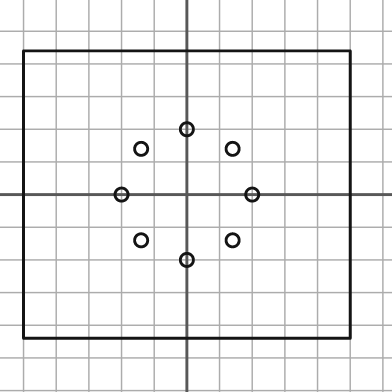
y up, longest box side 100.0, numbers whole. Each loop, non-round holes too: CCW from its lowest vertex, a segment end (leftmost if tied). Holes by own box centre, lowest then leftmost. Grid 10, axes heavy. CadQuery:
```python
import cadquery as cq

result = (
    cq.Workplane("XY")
    .moveTo(-50.0, -44.0)
    .lineTo(50.0, -44.0)
    .lineTo(50.0, 44.0)
    .lineTo(-50.0, 44.0)
    .close()
    .moveTo(0.0, -20.0)
    .circle(2.0)
    .moveTo(-14.0, -14.0)
    .circle(2.0)
    .moveTo(14.0, -14.0)
    .circle(2.0)
    .moveTo(-20.0, 0.0)
    .circle(2.0)
    .moveTo(20.0, 0.0)
    .circle(2.0)
    .moveTo(-14.0, 14.0)
    .circle(2.0)
    .moveTo(14.0, 14.0)
    .circle(2.0)
    .moveTo(0.0, 20.0)
    .circle(2.0)
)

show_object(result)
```